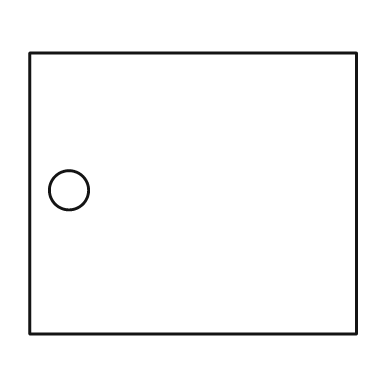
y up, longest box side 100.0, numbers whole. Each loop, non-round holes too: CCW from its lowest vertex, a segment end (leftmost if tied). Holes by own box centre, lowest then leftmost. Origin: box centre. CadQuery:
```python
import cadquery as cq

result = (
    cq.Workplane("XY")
    .moveTo(-50.0, -43.0)
    .lineTo(50.0, -43.0)
    .lineTo(50.0, 43.0)
    .lineTo(-50.0, 43.0)
    .close()
    .moveTo(-38.0, 1.0)
    .circle(6.0)
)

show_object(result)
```